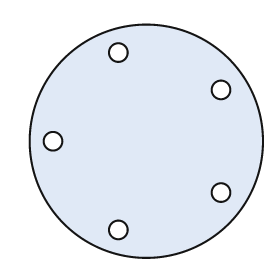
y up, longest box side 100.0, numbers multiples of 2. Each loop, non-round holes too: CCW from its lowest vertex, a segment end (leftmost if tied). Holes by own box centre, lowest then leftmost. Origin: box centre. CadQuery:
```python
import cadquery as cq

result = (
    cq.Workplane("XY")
    .moveTo(0.0, 0.0)
    .circle(50.0)
    .moveTo(-12.0, -38.0)
    .circle(4.0)
    .moveTo(32.0, -22.0)
    .circle(4.0)
    .moveTo(-40.0, 0.0)
    .circle(4.0)
    .moveTo(32.0, 22.0)
    .circle(4.0)
    .moveTo(-12.0, 38.0)
    .circle(4.0)
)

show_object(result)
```